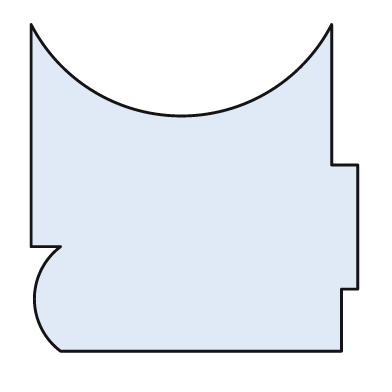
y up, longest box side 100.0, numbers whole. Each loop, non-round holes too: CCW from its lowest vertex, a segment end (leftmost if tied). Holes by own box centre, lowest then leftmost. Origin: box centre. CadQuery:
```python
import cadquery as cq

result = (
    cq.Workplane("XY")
    .moveTo(-41.0, -50.0)
    .lineTo(45.0, -50.0)
    .lineTo(45.0, -31.0)
    .lineTo(50.0, -31.0)
    .lineTo(50.0, 7.0)
    .lineTo(42.0, 7.0)
    .lineTo(42.0, 50.0)
    .threePointArc((-4.0, 22.0), (-50.0, 50.0))
    .lineTo(-50.0, -18.0)
    .lineTo(-41.0, -18.0)
    .threePointArc((-49.0, -34.0), (-41.0, -50.0))
    .close()
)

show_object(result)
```